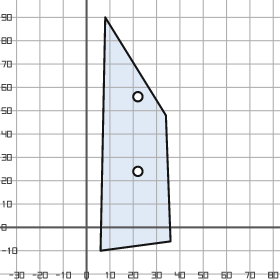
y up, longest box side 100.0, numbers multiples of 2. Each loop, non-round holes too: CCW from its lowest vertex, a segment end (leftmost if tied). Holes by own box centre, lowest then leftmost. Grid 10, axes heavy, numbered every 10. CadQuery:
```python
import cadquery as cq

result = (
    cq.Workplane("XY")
    .moveTo(6.0, -10.0)
    .lineTo(36.0, -6.0)
    .lineTo(34.0, 48.0)
    .lineTo(8.0, 90.0)
    .close()
    .moveTo(22.0, 24.0)
    .circle(2.0)
    .moveTo(22.0, 56.0)
    .circle(2.0)
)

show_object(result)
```